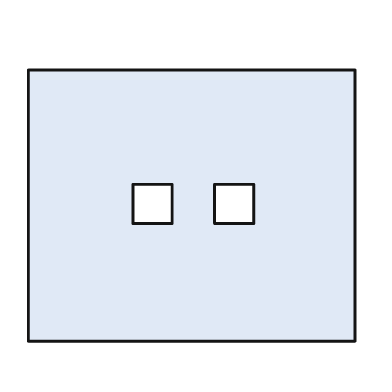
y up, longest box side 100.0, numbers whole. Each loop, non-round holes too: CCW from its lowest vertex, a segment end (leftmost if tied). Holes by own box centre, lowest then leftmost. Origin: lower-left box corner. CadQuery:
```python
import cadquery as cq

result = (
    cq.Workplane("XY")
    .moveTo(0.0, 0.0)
    .lineTo(100.0, 0.0)
    .lineTo(100.0, 83.0)
    .lineTo(0.0, 83.0)
    .close()
    .moveTo(32.0, 36.0)
    .lineTo(44.0, 36.0)
    .lineTo(44.0, 48.0)
    .lineTo(32.0, 48.0)
    .close()
    .moveTo(57.0, 36.0)
    .lineTo(69.0, 36.0)
    .lineTo(69.0, 48.0)
    .lineTo(57.0, 48.0)
    .close()
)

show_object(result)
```